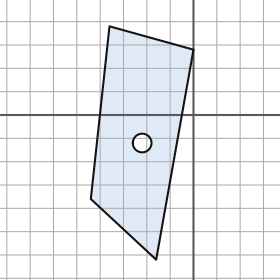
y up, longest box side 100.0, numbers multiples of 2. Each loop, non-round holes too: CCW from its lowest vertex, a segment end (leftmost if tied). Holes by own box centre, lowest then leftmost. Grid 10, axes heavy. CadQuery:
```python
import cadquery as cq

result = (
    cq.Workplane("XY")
    .moveTo(-16.0, -62.0)
    .lineTo(0.0, 28.0)
    .lineTo(-36.0, 38.0)
    .lineTo(-44.0, -36.0)
    .close()
    .moveTo(-22.0, -12.0)
    .circle(4.0)
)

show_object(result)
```